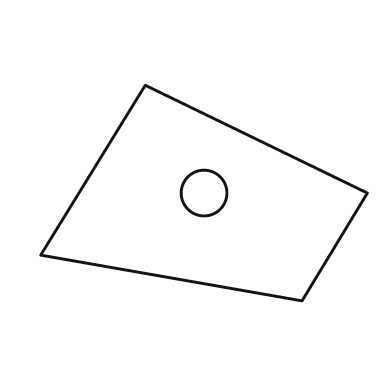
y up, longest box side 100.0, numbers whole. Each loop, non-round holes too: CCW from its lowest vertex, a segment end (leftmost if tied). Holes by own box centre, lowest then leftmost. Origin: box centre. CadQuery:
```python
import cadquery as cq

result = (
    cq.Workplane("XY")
    .moveTo(30.0, -33.0)
    .lineTo(50.0, 0.0)
    .lineTo(-18.0, 33.0)
    .lineTo(-50.0, -19.0)
    .close()
    .moveTo(0.0, 0.0)
    .circle(7.0)
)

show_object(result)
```